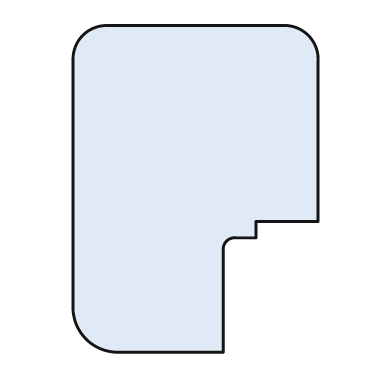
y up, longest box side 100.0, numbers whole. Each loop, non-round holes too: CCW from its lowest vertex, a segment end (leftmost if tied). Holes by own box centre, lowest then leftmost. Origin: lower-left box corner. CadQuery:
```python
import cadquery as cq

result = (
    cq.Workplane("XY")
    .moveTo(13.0, 0.0)
    .lineTo(46.0, 0.0)
    .lineTo(46.0, 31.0)
    .threePointArc((47.0, 34.0), (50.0, 35.0))
    .lineTo(56.0, 35.0)
    .lineTo(56.0, 40.0)
    .lineTo(75.0, 40.0)
    .lineTo(75.0, 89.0)
    .threePointArc((72.0, 97.0), (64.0, 100.0))
    .lineTo(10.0, 100.0)
    .threePointArc((3.0, 97.0), (0.0, 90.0))
    .lineTo(0.0, 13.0)
    .threePointArc((4.0, 4.0), (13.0, 0.0))
    .close()
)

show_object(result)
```